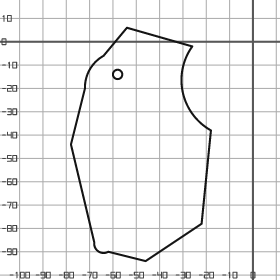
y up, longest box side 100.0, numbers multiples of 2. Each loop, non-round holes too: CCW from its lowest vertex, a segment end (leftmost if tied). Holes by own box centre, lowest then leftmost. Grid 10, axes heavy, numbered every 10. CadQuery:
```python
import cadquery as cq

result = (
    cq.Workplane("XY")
    .moveTo(-46.0, -94.0)
    .lineTo(-22.0, -78.0)
    .lineTo(-18.0, -38.0)
    .threePointArc((-30.0, -22.0), (-26.0, -2.0))
    .lineTo(-54.0, 6.0)
    .lineTo(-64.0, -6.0)
    .threePointArc((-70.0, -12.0), (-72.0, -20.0))
    .lineTo(-78.0, -44.0)
    .lineTo(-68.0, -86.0)
    .threePointArc((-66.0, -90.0), (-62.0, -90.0))
    .close()
    .moveTo(-58.0, -14.0)
    .circle(2.0)
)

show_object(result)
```